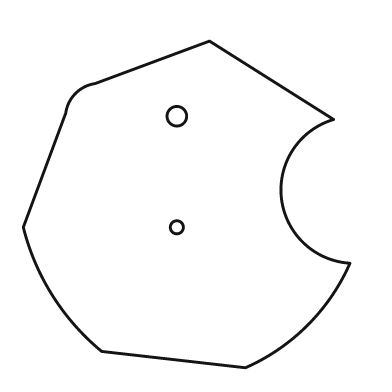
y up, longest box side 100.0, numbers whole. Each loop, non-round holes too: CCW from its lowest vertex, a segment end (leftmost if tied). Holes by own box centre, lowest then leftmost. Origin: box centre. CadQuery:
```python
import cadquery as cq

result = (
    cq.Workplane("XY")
    .moveTo(18.0, -50.0)
    .threePointArc((37.0, -37.0), (50.0, -18.0))
    .threePointArc((29.0, 2.0), (45.0, 26.0))
    .lineTo(7.0, 50.0)
    .lineTo(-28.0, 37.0)
    .threePointArc((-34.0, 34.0), (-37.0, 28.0))
    .lineTo(-50.0, -7.0)
    .threePointArc((-41.0, -28.0), (-26.0, -45.0))
    .close()
    .moveTo(-3.0, -7.0)
    .circle(2.0)
    .moveTo(-3.0, 27.0)
    .circle(3.0)
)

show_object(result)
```